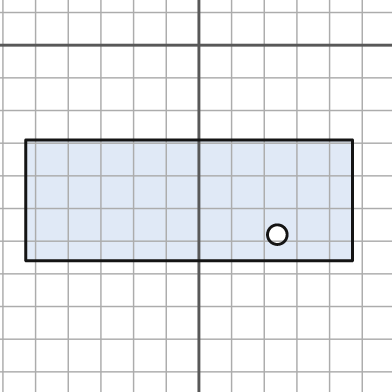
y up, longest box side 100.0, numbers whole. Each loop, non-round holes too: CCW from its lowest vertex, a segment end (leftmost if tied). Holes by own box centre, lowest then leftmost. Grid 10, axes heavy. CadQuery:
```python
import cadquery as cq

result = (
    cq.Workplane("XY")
    .moveTo(-53.0, -66.0)
    .lineTo(47.0, -66.0)
    .lineTo(47.0, -29.0)
    .lineTo(-53.0, -29.0)
    .close()
    .moveTo(24.0, -58.0)
    .circle(3.0)
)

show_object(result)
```